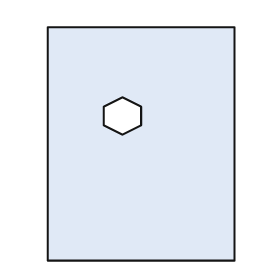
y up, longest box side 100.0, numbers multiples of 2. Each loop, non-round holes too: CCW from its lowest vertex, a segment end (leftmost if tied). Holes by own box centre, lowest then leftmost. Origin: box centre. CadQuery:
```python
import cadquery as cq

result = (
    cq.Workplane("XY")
    .moveTo(-40.0, -50.0)
    .lineTo(40.0, -50.0)
    .lineTo(40.0, 50.0)
    .lineTo(-40.0, 50.0)
    .close()
    .moveTo(-8.0, 4.0)
    .lineTo(0.0, 8.0)
    .lineTo(0.0, 16.0)
    .lineTo(-8.0, 20.0)
    .lineTo(-16.0, 16.0)
    .lineTo(-16.0, 8.0)
    .close()
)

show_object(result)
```